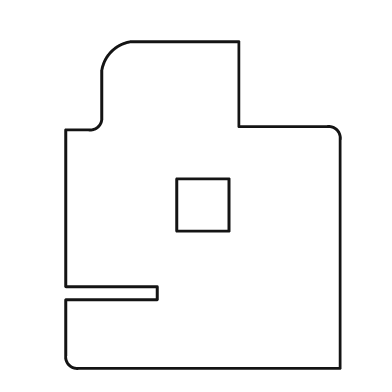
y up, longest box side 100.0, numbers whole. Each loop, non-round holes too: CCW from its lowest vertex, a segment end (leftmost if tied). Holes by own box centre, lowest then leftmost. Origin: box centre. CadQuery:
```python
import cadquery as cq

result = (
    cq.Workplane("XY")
    .moveTo(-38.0, -50.0)
    .lineTo(42.0, -50.0)
    .lineTo(42.0, 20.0)
    .threePointArc((41.0, 23.0), (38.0, 24.0))
    .lineTo(11.0, 24.0)
    .lineTo(11.0, 50.0)
    .lineTo(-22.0, 50.0)
    .threePointArc((-28.0, 47.0), (-31.0, 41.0))
    .lineTo(-31.0, 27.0)
    .threePointArc((-32.0, 24.0), (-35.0, 23.0))
    .lineTo(-42.0, 23.0)
    .lineTo(-42.0, -25.0)
    .lineTo(-14.0, -25.0)
    .lineTo(-14.0, -29.0)
    .lineTo(-42.0, -29.0)
    .lineTo(-42.0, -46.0)
    .threePointArc((-41.0, -49.0), (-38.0, -50.0))
    .close()
    .moveTo(-8.0, -8.0)
    .lineTo(8.0, -8.0)
    .lineTo(8.0, 8.0)
    .lineTo(-8.0, 8.0)
    .close()
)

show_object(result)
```